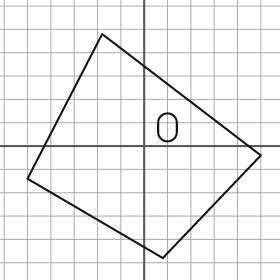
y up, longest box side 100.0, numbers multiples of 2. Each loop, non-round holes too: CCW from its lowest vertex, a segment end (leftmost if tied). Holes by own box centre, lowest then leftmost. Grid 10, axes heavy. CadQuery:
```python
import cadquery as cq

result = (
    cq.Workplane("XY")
    .moveTo(8.0, -48.0)
    .lineTo(50.0, -4.0)
    .lineTo(-18.0, 48.0)
    .lineTo(-50.0, -14.0)
    .close()
    .moveTo(6.0, 6.0)
    .threePointArc((10.0, 2.0), (14.0, 6.0))
    .lineTo(14.0, 10.0)
    .threePointArc((10.0, 14.0), (6.0, 10.0))
    .close()
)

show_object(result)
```